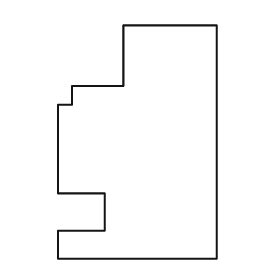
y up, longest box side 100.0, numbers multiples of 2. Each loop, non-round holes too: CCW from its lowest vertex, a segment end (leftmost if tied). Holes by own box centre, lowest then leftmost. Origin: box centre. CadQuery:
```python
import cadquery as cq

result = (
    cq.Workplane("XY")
    .moveTo(-34.0, -50.0)
    .lineTo(34.0, -50.0)
    .lineTo(34.0, 50.0)
    .lineTo(-6.0, 50.0)
    .lineTo(-6.0, 24.0)
    .lineTo(-28.0, 24.0)
    .lineTo(-28.0, 16.0)
    .lineTo(-34.0, 16.0)
    .lineTo(-34.0, -22.0)
    .lineTo(-14.0, -22.0)
    .lineTo(-14.0, -38.0)
    .lineTo(-34.0, -38.0)
    .close()
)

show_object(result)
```